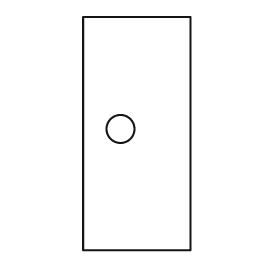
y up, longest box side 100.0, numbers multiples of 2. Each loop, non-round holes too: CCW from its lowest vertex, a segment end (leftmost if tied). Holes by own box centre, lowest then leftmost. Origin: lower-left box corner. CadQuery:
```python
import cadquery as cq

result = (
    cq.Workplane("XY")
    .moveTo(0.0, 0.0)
    .lineTo(46.0, 0.0)
    .lineTo(46.0, 100.0)
    .lineTo(0.0, 100.0)
    .close()
    .moveTo(16.0, 52.0)
    .circle(6.0)
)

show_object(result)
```